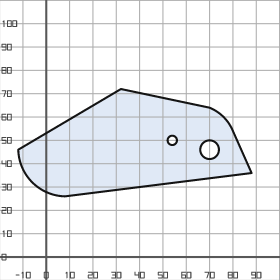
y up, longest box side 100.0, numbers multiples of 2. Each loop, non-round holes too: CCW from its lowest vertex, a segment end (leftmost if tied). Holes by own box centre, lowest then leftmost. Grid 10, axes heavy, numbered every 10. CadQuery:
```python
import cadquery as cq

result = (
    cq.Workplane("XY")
    .moveTo(8.0, 26.0)
    .lineTo(88.0, 36.0)
    .lineTo(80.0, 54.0)
    .threePointArc((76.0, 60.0), (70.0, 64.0))
    .lineTo(32.0, 72.0)
    .lineTo(-12.0, 46.0)
    .threePointArc((-6.0, 32.0), (8.0, 26.0))
    .close()
    .moveTo(70.0, 46.0)
    .circle(4.0)
    .moveTo(54.0, 50.0)
    .circle(2.0)
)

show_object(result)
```